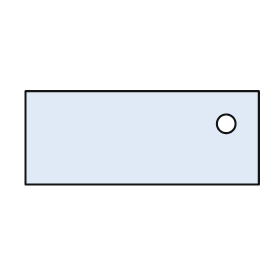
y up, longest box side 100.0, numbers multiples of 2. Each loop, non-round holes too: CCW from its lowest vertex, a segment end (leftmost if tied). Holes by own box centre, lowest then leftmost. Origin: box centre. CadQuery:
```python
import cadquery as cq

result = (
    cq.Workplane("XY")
    .moveTo(-50.0, -20.0)
    .lineTo(50.0, -20.0)
    .lineTo(50.0, 20.0)
    .lineTo(-50.0, 20.0)
    .close()
    .moveTo(36.0, 6.0)
    .circle(4.0)
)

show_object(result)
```